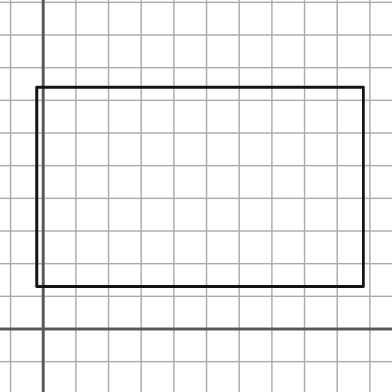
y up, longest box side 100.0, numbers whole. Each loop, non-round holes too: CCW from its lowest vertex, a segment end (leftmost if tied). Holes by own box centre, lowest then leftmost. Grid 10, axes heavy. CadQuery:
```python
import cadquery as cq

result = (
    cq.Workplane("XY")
    .moveTo(-2.0, 13.0)
    .lineTo(98.0, 13.0)
    .lineTo(98.0, 74.0)
    .lineTo(-2.0, 74.0)
    .close()
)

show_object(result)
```